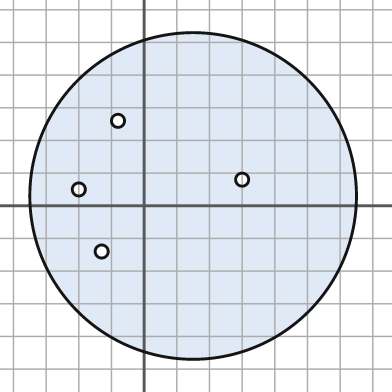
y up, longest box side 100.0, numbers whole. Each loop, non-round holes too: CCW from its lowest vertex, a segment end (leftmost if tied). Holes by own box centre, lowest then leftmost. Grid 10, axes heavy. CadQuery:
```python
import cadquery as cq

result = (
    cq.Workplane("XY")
    .moveTo(15.0, 3.0)
    .circle(50.0)
    .moveTo(-13.0, -14.0)
    .circle(2.0)
    .moveTo(-20.0, 5.0)
    .circle(2.0)
    .moveTo(30.0, 8.0)
    .circle(2.0)
    .moveTo(-8.0, 26.0)
    .circle(2.0)
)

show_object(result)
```